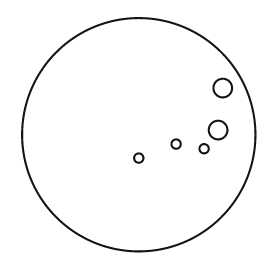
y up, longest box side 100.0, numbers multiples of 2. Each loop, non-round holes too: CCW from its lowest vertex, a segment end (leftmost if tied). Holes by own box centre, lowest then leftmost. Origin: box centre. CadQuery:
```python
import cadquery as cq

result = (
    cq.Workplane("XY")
    .moveTo(0.0, 0.0)
    .circle(50.0)
    .moveTo(0.0, -10.0)
    .circle(2.0)
    .moveTo(28.0, -6.0)
    .circle(2.0)
    .moveTo(16.0, -4.0)
    .circle(2.0)
    .moveTo(34.0, 2.0)
    .circle(4.0)
    .moveTo(36.0, 20.0)
    .circle(4.0)
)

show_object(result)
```